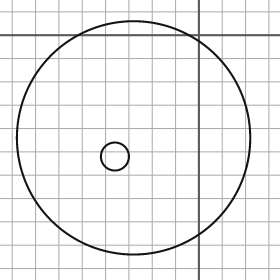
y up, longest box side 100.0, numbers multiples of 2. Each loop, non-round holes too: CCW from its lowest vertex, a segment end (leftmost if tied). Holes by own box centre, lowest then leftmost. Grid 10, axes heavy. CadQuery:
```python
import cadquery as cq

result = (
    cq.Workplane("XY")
    .moveTo(-28.0, -44.0)
    .circle(50.0)
    .moveTo(-36.0, -52.0)
    .circle(6.0)
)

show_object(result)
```